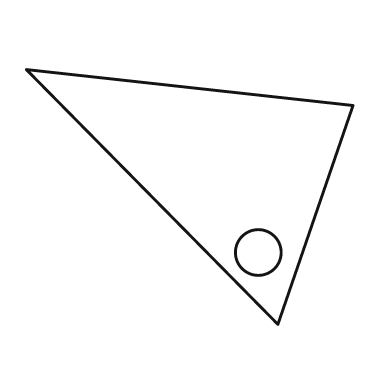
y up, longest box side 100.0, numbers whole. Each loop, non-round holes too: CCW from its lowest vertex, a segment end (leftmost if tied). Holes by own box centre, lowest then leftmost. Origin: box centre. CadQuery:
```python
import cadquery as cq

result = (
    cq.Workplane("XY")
    .moveTo(27.0, -39.0)
    .lineTo(50.0, 28.0)
    .lineTo(-50.0, 39.0)
    .close()
    .moveTo(21.0, -17.0)
    .circle(7.0)
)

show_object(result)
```